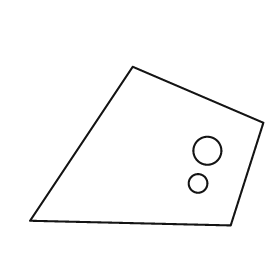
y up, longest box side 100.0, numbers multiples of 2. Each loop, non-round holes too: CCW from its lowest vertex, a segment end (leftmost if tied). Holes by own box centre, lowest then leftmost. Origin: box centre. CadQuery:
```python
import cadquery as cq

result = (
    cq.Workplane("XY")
    .moveTo(36.0, -34.0)
    .lineTo(50.0, 10.0)
    .lineTo(-6.0, 34.0)
    .lineTo(-50.0, -32.0)
    .close()
    .moveTo(22.0, -16.0)
    .circle(4.0)
    .moveTo(26.0, -2.0)
    .circle(6.0)
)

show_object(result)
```